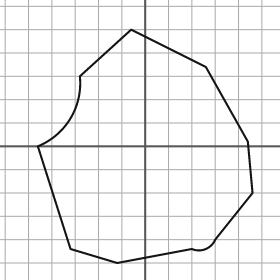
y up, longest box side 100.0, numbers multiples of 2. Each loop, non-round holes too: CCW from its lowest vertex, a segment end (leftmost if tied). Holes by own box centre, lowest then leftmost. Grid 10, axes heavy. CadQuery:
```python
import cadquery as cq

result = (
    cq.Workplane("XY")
    .moveTo(-12.0, -50.0)
    .lineTo(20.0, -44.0)
    .threePointArc((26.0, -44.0), (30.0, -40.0))
    .lineTo(46.0, -20.0)
    .lineTo(44.0, 2.0)
    .lineTo(26.0, 34.0)
    .lineTo(-6.0, 50.0)
    .lineTo(-28.0, 30.0)
    .threePointArc((-32.0, 12.0), (-46.0, 0.0))
    .lineTo(-32.0, -44.0)
    .close()
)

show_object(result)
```